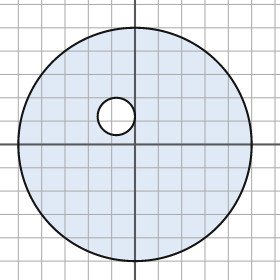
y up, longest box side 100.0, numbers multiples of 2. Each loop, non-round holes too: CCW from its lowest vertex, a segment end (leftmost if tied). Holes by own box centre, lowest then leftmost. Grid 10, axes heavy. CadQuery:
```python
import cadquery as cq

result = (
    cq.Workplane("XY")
    .moveTo(0.0, 0.0)
    .circle(50.0)
    .moveTo(-8.0, 12.0)
    .circle(8.0)
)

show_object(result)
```